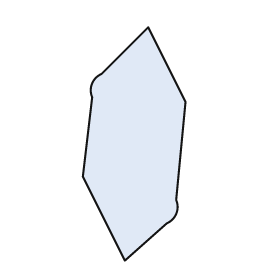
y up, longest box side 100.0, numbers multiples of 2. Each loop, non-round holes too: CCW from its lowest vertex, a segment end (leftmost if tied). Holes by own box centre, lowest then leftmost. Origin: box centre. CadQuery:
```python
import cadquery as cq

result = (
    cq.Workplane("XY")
    .moveTo(-4.0, -50.0)
    .lineTo(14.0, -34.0)
    .threePointArc((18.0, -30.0), (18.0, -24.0))
    .lineTo(22.0, 18.0)
    .lineTo(6.0, 50.0)
    .lineTo(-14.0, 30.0)
    .threePointArc((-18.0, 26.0), (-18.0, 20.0))
    .lineTo(-22.0, -14.0)
    .close()
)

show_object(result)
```